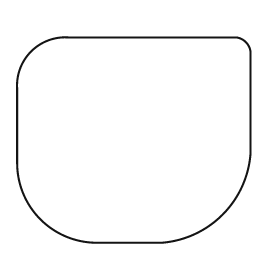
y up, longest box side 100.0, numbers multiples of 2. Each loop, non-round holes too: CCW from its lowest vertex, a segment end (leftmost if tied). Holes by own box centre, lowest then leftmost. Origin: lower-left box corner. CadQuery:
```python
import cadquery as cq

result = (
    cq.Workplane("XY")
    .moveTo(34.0, 0.0)
    .lineTo(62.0, 0.0)
    .threePointArc((88.0, 12.0), (100.0, 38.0))
    .lineTo(100.0, 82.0)
    .threePointArc((98.0, 86.0), (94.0, 88.0))
    .lineTo(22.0, 88.0)
    .threePointArc((6.0, 82.0), (0.0, 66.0))
    .lineTo(0.0, 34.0)
    .threePointArc((10.0, 10.0), (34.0, 0.0))
    .close()
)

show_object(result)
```